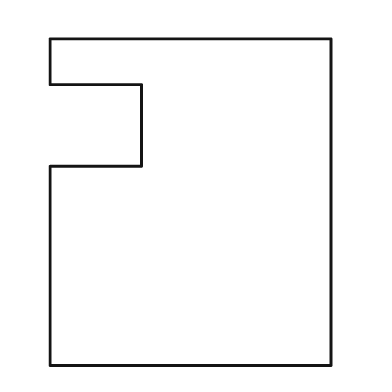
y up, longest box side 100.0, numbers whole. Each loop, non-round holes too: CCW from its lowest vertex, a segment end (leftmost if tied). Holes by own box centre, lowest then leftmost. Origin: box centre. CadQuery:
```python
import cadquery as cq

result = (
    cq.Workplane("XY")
    .moveTo(-43.0, -50.0)
    .lineTo(43.0, -50.0)
    .lineTo(43.0, 50.0)
    .lineTo(-43.0, 50.0)
    .lineTo(-43.0, 36.0)
    .lineTo(-15.0, 36.0)
    .lineTo(-15.0, 11.0)
    .lineTo(-43.0, 11.0)
    .close()
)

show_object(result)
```